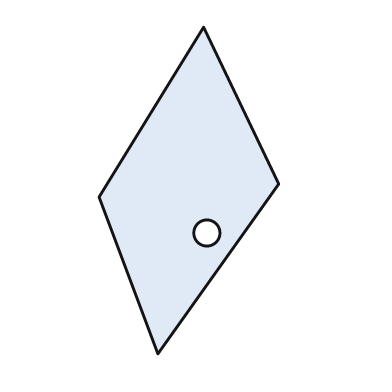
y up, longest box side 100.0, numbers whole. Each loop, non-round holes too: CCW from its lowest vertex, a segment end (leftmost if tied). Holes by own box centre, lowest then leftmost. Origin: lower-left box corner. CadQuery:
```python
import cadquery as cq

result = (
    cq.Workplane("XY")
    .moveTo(18.0, 0.0)
    .lineTo(55.0, 52.0)
    .lineTo(32.0, 100.0)
    .lineTo(0.0, 48.0)
    .close()
    .moveTo(33.0, 37.0)
    .circle(4.0)
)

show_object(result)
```